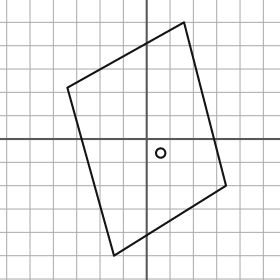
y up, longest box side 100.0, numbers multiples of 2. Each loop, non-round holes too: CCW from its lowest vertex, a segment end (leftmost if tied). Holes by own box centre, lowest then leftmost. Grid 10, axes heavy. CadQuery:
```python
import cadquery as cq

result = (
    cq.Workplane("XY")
    .moveTo(-14.0, -50.0)
    .lineTo(34.0, -20.0)
    .lineTo(16.0, 50.0)
    .lineTo(-34.0, 22.0)
    .close()
    .moveTo(6.0, -6.0)
    .circle(2.0)
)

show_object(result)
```